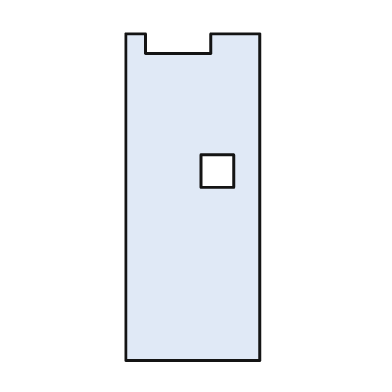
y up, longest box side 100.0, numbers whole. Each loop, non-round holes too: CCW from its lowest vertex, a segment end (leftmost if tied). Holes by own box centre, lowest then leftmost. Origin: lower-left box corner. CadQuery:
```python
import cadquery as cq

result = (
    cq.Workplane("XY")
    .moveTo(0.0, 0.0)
    .lineTo(41.0, 0.0)
    .lineTo(41.0, 100.0)
    .lineTo(26.0, 100.0)
    .lineTo(26.0, 94.0)
    .lineTo(6.0, 94.0)
    .lineTo(6.0, 100.0)
    .lineTo(0.0, 100.0)
    .close()
    .moveTo(23.0, 53.0)
    .lineTo(33.0, 53.0)
    .lineTo(33.0, 63.0)
    .lineTo(23.0, 63.0)
    .close()
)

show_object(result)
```